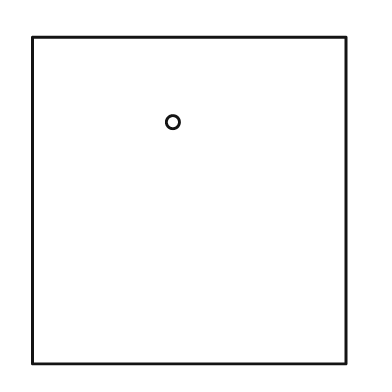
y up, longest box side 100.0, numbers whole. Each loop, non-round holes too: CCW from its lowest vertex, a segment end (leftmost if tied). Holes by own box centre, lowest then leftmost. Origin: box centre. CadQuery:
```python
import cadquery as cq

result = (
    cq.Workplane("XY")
    .moveTo(-48.0, -50.0)
    .lineTo(48.0, -50.0)
    .lineTo(48.0, 50.0)
    .lineTo(-48.0, 50.0)
    .close()
    .moveTo(-5.0, 24.0)
    .circle(2.0)
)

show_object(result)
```